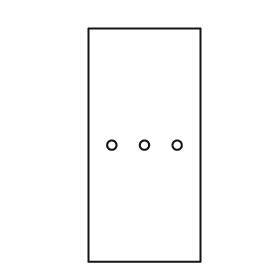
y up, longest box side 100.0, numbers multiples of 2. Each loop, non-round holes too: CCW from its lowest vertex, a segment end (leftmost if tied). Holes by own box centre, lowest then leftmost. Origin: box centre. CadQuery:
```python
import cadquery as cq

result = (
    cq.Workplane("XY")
    .moveTo(-24.0, -50.0)
    .lineTo(24.0, -50.0)
    .lineTo(24.0, 50.0)
    .lineTo(-24.0, 50.0)
    .close()
    .moveTo(-14.0, 0.0)
    .circle(2.0)
    .moveTo(0.0, 0.0)
    .circle(2.0)
    .moveTo(14.0, 0.0)
    .circle(2.0)
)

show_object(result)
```